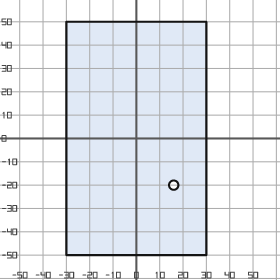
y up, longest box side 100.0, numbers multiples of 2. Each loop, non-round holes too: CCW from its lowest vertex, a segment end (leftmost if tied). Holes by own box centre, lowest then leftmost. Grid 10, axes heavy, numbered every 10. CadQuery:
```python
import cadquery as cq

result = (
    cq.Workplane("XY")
    .moveTo(-30.0, -50.0)
    .lineTo(30.0, -50.0)
    .lineTo(30.0, 50.0)
    .lineTo(-30.0, 50.0)
    .close()
    .moveTo(16.0, -20.0)
    .circle(2.0)
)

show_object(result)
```